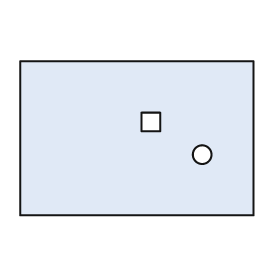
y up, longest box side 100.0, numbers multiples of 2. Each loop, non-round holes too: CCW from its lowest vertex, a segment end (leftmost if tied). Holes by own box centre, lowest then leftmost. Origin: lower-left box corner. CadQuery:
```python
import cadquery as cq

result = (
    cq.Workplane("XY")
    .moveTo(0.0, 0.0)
    .lineTo(100.0, 0.0)
    .lineTo(100.0, 66.0)
    .lineTo(0.0, 66.0)
    .close()
    .moveTo(78.0, 26.0)
    .circle(4.0)
    .moveTo(52.0, 36.0)
    .lineTo(60.0, 36.0)
    .lineTo(60.0, 44.0)
    .lineTo(52.0, 44.0)
    .close()
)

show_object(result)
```